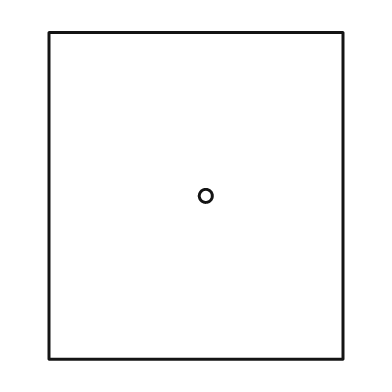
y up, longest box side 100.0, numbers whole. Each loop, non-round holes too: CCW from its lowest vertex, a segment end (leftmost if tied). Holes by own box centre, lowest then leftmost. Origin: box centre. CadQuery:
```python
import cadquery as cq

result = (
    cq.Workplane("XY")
    .moveTo(-45.0, -50.0)
    .lineTo(45.0, -50.0)
    .lineTo(45.0, 50.0)
    .lineTo(-45.0, 50.0)
    .close()
    .moveTo(3.0, 0.0)
    .circle(2.0)
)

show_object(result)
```